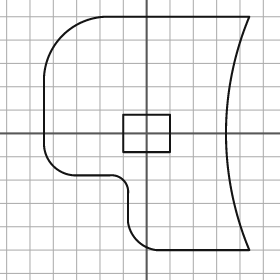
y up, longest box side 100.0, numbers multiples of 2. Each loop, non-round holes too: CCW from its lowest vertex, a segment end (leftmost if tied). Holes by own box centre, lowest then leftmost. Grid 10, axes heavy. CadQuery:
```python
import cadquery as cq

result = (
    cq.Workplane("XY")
    .moveTo(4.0, -50.0)
    .lineTo(44.0, -50.0)
    .threePointArc((34.0, 0.0), (44.0, 50.0))
    .lineTo(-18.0, 50.0)
    .threePointArc((-36.0, 42.0), (-44.0, 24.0))
    .lineTo(-44.0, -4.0)
    .threePointArc((-40.0, -14.0), (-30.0, -18.0))
    .lineTo(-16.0, -18.0)
    .threePointArc((-10.0, -20.0), (-8.0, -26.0))
    .lineTo(-8.0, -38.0)
    .threePointArc((-4.0, -46.0), (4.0, -50.0))
    .close()
    .moveTo(-10.0, -8.0)
    .lineTo(10.0, -8.0)
    .lineTo(10.0, 8.0)
    .lineTo(-10.0, 8.0)
    .close()
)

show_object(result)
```